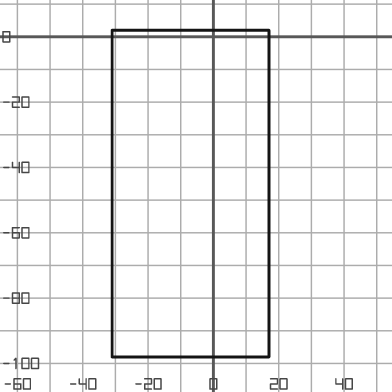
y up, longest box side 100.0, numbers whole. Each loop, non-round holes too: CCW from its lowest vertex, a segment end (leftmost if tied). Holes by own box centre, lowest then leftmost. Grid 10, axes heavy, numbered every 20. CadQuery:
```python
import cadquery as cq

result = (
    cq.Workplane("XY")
    .moveTo(-31.0, -98.0)
    .lineTo(17.0, -98.0)
    .lineTo(17.0, 2.0)
    .lineTo(-31.0, 2.0)
    .close()
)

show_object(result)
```